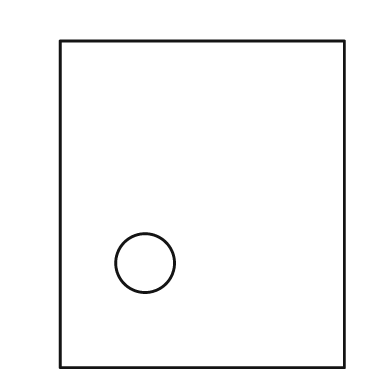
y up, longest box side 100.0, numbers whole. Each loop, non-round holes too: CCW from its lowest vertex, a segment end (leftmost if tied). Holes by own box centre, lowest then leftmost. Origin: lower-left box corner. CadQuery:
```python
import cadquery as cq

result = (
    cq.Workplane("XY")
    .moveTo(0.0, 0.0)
    .lineTo(87.0, 0.0)
    .lineTo(87.0, 100.0)
    .lineTo(0.0, 100.0)
    .close()
    .moveTo(26.0, 32.0)
    .circle(9.0)
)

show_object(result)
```